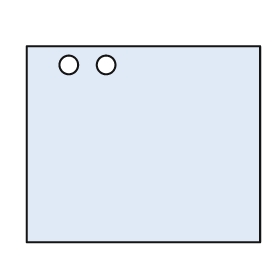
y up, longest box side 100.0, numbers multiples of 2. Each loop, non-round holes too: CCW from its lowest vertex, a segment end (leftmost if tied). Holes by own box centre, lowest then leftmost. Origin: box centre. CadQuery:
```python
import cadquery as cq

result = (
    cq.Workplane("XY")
    .moveTo(-50.0, -42.0)
    .lineTo(50.0, -42.0)
    .lineTo(50.0, 42.0)
    .lineTo(-50.0, 42.0)
    .close()
    .moveTo(-32.0, 34.0)
    .circle(4.0)
    .moveTo(-16.0, 34.0)
    .circle(4.0)
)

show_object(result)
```